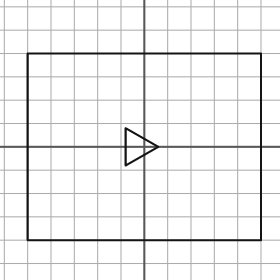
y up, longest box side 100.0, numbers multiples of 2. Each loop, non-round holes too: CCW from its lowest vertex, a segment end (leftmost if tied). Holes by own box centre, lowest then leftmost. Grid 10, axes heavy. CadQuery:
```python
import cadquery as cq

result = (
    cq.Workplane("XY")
    .moveTo(-50.0, -40.0)
    .lineTo(50.0, -40.0)
    .lineTo(50.0, 40.0)
    .lineTo(-50.0, 40.0)
    .close()
    .moveTo(-8.0, -8.0)
    .lineTo(6.0, 0.0)
    .lineTo(-8.0, 8.0)
    .close()
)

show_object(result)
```